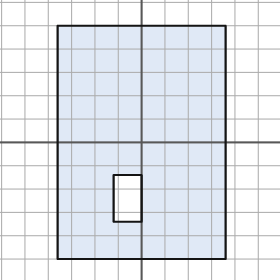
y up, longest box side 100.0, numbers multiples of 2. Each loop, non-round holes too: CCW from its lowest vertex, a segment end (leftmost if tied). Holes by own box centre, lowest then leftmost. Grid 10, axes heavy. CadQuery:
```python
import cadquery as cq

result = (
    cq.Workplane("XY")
    .moveTo(-36.0, -50.0)
    .lineTo(36.0, -50.0)
    .lineTo(36.0, 50.0)
    .lineTo(-36.0, 50.0)
    .close()
    .moveTo(-12.0, -34.0)
    .lineTo(0.0, -34.0)
    .lineTo(0.0, -14.0)
    .lineTo(-12.0, -14.0)
    .close()
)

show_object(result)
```